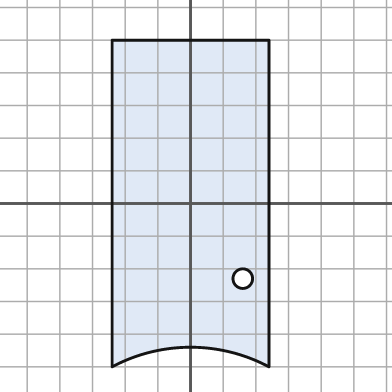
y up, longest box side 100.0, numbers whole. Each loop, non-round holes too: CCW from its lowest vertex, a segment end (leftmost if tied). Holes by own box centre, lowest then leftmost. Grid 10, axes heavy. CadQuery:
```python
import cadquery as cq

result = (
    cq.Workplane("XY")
    .moveTo(-24.0, -50.0)
    .threePointArc((0.0, -44.0), (24.0, -50.0))
    .lineTo(24.0, 50.0)
    .lineTo(-24.0, 50.0)
    .close()
    .moveTo(16.0, -23.0)
    .circle(3.0)
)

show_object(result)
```